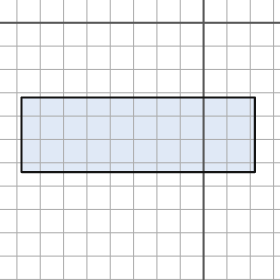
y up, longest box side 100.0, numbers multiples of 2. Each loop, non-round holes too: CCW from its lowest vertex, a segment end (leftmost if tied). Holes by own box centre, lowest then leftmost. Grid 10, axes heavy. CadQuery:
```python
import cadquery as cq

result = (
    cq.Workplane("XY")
    .moveTo(-78.0, -64.0)
    .lineTo(22.0, -64.0)
    .lineTo(22.0, -32.0)
    .lineTo(-78.0, -32.0)
    .close()
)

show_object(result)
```